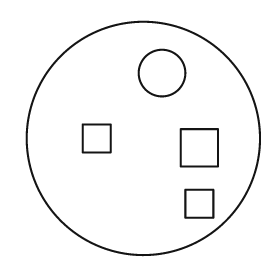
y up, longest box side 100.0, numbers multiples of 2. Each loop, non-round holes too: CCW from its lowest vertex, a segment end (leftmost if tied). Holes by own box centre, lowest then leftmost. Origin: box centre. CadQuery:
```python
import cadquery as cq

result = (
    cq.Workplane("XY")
    .moveTo(0.0, 0.0)
    .circle(50.0)
    .moveTo(18.0, -34.0)
    .lineTo(30.0, -34.0)
    .lineTo(30.0, -22.0)
    .lineTo(18.0, -22.0)
    .close()
    .moveTo(16.0, -12.0)
    .lineTo(32.0, -12.0)
    .lineTo(32.0, 4.0)
    .lineTo(16.0, 4.0)
    .close()
    .moveTo(-26.0, -6.0)
    .lineTo(-14.0, -6.0)
    .lineTo(-14.0, 6.0)
    .lineTo(-26.0, 6.0)
    .close()
    .moveTo(8.0, 28.0)
    .circle(10.0)
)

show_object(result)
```